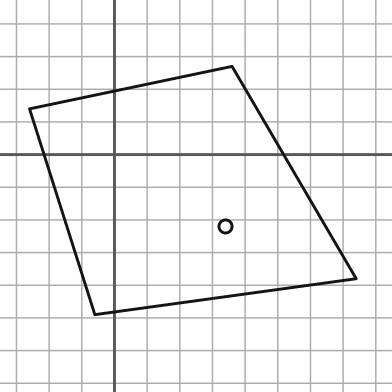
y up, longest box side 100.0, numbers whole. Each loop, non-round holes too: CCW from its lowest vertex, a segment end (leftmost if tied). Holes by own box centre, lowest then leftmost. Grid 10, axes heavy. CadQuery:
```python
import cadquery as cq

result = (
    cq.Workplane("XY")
    .moveTo(-6.0, -49.0)
    .lineTo(74.0, -38.0)
    .lineTo(36.0, 27.0)
    .lineTo(-26.0, 14.0)
    .close()
    .moveTo(34.0, -22.0)
    .circle(2.0)
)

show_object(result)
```